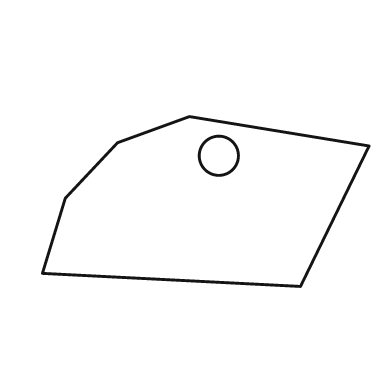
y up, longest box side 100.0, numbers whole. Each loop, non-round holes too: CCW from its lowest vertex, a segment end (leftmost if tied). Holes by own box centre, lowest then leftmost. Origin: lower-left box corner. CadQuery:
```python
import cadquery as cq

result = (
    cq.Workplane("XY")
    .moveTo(79.0, 0.0)
    .lineTo(100.0, 43.0)
    .lineTo(45.0, 52.0)
    .lineTo(23.0, 44.0)
    .lineTo(7.0, 27.0)
    .lineTo(0.0, 4.0)
    .close()
    .moveTo(54.0, 40.0)
    .circle(6.0)
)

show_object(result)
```